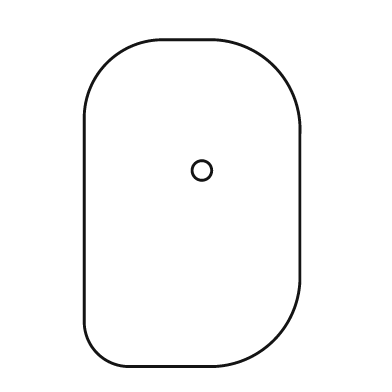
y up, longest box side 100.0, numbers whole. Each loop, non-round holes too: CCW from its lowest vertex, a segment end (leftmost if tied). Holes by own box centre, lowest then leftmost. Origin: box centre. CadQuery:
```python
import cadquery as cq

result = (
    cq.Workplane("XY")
    .moveTo(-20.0, -50.0)
    .lineTo(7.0, -50.0)
    .threePointArc((25.0, -42.0), (33.0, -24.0))
    .lineTo(33.0, 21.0)
    .threePointArc((25.0, 42.0), (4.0, 50.0))
    .lineTo(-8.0, 50.0)
    .threePointArc((-26.0, 43.0), (-33.0, 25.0))
    .lineTo(-33.0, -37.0)
    .threePointArc((-29.0, -46.0), (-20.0, -50.0))
    .close()
    .moveTo(3.0, 10.0)
    .circle(3.0)
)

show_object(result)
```